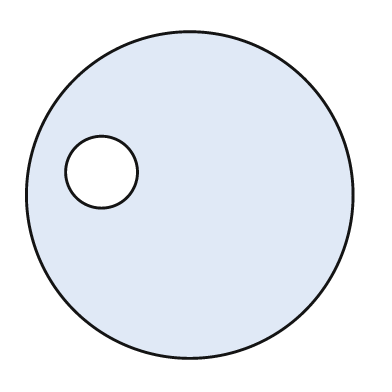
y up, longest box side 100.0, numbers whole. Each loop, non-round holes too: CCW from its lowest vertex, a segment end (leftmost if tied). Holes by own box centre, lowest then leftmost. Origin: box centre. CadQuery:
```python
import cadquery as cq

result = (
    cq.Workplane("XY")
    .moveTo(0.0, 0.0)
    .circle(50.0)
    .moveTo(-27.0, 7.0)
    .circle(11.0)
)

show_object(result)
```